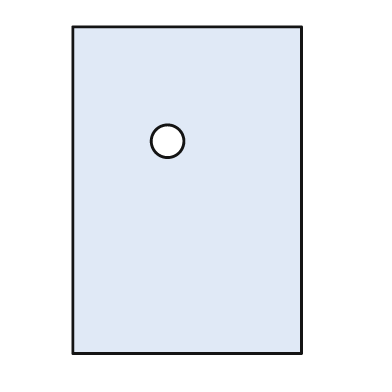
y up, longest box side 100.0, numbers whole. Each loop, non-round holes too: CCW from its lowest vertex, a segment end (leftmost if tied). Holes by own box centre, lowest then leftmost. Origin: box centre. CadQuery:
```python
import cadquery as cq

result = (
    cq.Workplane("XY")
    .moveTo(-35.0, -50.0)
    .lineTo(35.0, -50.0)
    .lineTo(35.0, 50.0)
    .lineTo(-35.0, 50.0)
    .close()
    .moveTo(-6.0, 15.0)
    .circle(5.0)
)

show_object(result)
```